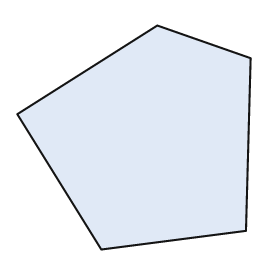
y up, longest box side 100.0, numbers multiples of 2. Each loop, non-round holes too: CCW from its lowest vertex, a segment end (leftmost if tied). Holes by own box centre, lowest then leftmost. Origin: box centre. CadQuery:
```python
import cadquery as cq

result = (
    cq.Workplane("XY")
    .moveTo(-14.0, -48.0)
    .lineTo(48.0, -40.0)
    .lineTo(50.0, 34.0)
    .lineTo(10.0, 48.0)
    .lineTo(-50.0, 10.0)
    .close()
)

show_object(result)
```